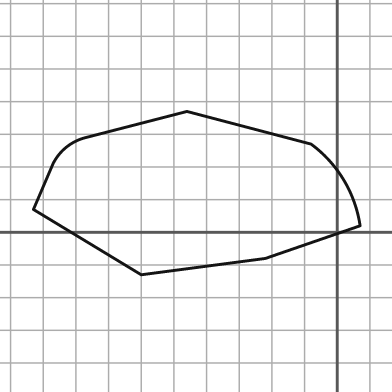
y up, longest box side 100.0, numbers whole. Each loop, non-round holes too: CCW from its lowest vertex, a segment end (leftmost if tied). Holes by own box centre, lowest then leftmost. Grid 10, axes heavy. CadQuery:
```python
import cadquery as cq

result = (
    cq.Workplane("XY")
    .moveTo(-60.0, -13.0)
    .lineTo(-22.0, -8.0)
    .lineTo(7.0, 2.0)
    .threePointArc((2.0, 16.0), (-8.0, 27.0))
    .lineTo(-46.0, 37.0)
    .lineTo(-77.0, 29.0)
    .threePointArc((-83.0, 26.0), (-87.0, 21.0))
    .lineTo(-93.0, 7.0)
    .close()
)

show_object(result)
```